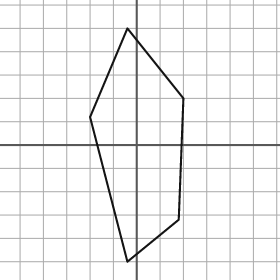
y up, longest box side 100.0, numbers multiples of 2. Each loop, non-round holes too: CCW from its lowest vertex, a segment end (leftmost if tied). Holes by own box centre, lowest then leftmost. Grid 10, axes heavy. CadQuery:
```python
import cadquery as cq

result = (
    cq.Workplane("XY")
    .moveTo(-4.0, -50.0)
    .lineTo(18.0, -32.0)
    .lineTo(20.0, 20.0)
    .lineTo(-4.0, 50.0)
    .lineTo(-20.0, 12.0)
    .close()
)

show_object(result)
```